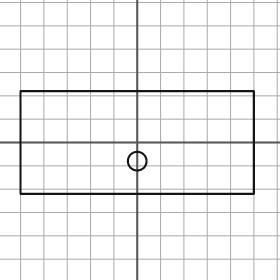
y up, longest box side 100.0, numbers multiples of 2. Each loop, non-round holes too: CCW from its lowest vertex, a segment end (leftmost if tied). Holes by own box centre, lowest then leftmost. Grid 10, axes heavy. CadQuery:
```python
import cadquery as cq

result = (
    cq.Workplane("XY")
    .moveTo(-50.0, -22.0)
    .lineTo(50.0, -22.0)
    .lineTo(50.0, 22.0)
    .lineTo(-50.0, 22.0)
    .close()
    .moveTo(0.0, -8.0)
    .circle(4.0)
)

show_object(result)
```